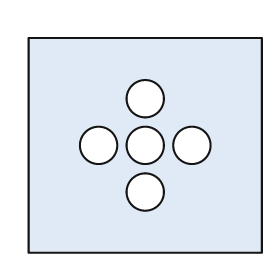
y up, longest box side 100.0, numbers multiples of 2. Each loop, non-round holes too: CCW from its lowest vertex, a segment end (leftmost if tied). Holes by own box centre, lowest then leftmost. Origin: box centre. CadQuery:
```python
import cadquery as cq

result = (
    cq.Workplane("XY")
    .moveTo(-50.0, -46.0)
    .lineTo(50.0, -46.0)
    .lineTo(50.0, 46.0)
    .lineTo(-50.0, 46.0)
    .close()
    .moveTo(0.0, -20.0)
    .circle(8.0)
    .moveTo(-20.0, 0.0)
    .circle(8.0)
    .moveTo(0.0, 0.0)
    .circle(8.0)
    .moveTo(20.0, 0.0)
    .circle(8.0)
    .moveTo(0.0, 20.0)
    .circle(8.0)
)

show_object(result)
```